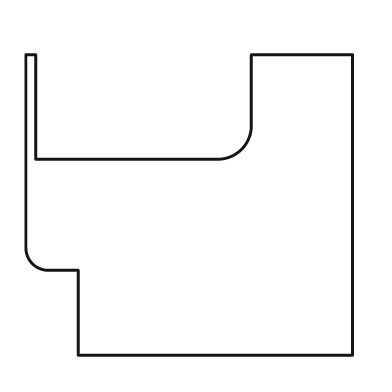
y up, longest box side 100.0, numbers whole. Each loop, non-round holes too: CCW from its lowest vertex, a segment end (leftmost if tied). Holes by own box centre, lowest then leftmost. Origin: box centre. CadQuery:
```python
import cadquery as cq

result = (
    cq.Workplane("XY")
    .moveTo(-34.0, -46.0)
    .lineTo(50.0, -46.0)
    .lineTo(50.0, 46.0)
    .lineTo(19.0, 46.0)
    .lineTo(19.0, 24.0)
    .threePointArc((16.0, 17.0), (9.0, 14.0))
    .lineTo(-47.0, 14.0)
    .lineTo(-47.0, 46.0)
    .lineTo(-50.0, 46.0)
    .lineTo(-50.0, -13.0)
    .threePointArc((-48.0, -18.0), (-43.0, -20.0))
    .lineTo(-34.0, -20.0)
    .close()
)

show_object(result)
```